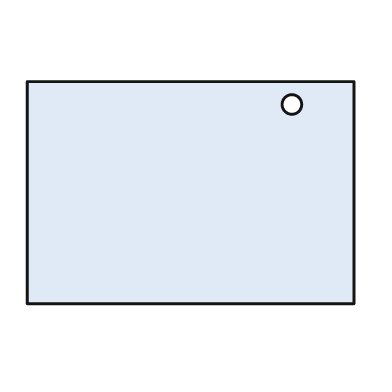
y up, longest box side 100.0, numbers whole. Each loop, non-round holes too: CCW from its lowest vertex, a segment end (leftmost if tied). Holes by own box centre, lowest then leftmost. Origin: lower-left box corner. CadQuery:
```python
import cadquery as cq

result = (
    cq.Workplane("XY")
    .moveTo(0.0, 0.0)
    .lineTo(100.0, 0.0)
    .lineTo(100.0, 68.0)
    .lineTo(0.0, 68.0)
    .close()
    .moveTo(81.0, 61.0)
    .circle(3.0)
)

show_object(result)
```